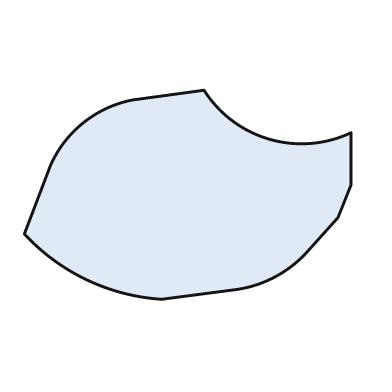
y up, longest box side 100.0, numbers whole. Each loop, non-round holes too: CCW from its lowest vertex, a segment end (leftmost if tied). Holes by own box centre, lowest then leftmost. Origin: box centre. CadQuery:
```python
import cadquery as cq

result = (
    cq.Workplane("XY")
    .moveTo(-8.0, -32.0)
    .lineTo(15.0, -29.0)
    .threePointArc((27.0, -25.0), (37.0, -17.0))
    .lineTo(46.0, -7.0)
    .lineTo(50.0, 3.0)
    .lineTo(50.0, 19.0)
    .threePointArc((25.0, 17.0), (5.0, 32.0))
    .lineTo(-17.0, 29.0)
    .threePointArc((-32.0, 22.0), (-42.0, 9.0))
    .lineTo(-50.0, -12.0)
    .threePointArc((-31.0, -26.0), (-8.0, -32.0))
    .close()
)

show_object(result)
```